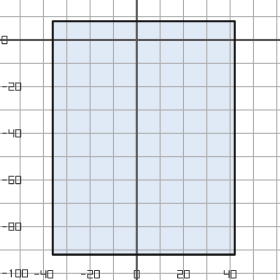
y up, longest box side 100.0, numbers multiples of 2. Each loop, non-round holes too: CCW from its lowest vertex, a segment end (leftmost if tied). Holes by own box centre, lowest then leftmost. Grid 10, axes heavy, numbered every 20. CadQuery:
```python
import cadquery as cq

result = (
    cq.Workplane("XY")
    .moveTo(-36.0, -92.0)
    .lineTo(42.0, -92.0)
    .lineTo(42.0, 8.0)
    .lineTo(-36.0, 8.0)
    .close()
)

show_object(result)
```